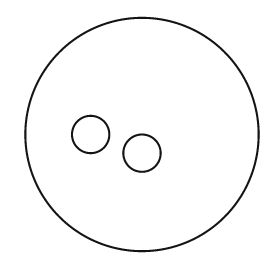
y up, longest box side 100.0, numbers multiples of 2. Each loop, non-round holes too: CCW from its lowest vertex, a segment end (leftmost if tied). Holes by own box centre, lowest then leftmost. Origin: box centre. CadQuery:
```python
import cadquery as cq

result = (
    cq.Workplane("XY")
    .moveTo(0.0, 0.0)
    .circle(50.0)
    .moveTo(0.0, -8.0)
    .circle(8.0)
    .moveTo(-22.0, 0.0)
    .circle(8.0)
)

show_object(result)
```